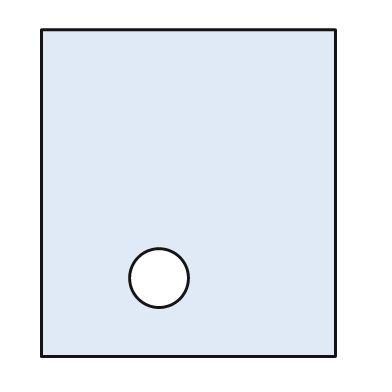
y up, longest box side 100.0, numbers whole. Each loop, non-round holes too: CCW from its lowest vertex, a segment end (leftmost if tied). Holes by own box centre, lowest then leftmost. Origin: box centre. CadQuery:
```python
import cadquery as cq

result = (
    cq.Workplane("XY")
    .moveTo(-45.0, -50.0)
    .lineTo(45.0, -50.0)
    .lineTo(45.0, 50.0)
    .lineTo(-45.0, 50.0)
    .close()
    .moveTo(-9.0, -26.0)
    .circle(9.0)
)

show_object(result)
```